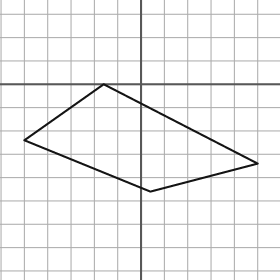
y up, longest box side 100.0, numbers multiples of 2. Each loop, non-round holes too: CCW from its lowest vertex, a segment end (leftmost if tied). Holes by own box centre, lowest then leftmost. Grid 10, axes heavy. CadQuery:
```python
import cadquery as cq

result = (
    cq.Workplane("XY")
    .moveTo(4.0, -46.0)
    .lineTo(50.0, -34.0)
    .lineTo(-16.0, 0.0)
    .lineTo(-50.0, -24.0)
    .close()
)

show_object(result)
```